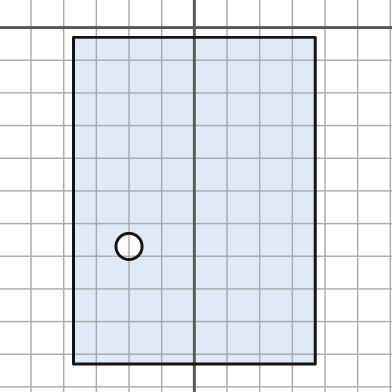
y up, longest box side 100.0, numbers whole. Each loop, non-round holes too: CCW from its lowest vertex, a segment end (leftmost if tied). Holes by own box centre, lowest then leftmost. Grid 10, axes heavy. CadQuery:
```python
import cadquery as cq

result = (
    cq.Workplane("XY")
    .moveTo(-37.0, -103.0)
    .lineTo(37.0, -103.0)
    .lineTo(37.0, -3.0)
    .lineTo(-37.0, -3.0)
    .close()
    .moveTo(-20.0, -67.0)
    .circle(4.0)
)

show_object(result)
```